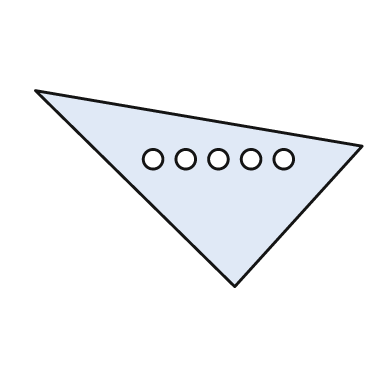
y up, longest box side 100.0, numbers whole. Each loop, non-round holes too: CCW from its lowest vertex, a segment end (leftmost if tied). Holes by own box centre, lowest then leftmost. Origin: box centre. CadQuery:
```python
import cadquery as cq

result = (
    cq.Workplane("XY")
    .moveTo(11.0, -30.0)
    .lineTo(50.0, 13.0)
    .lineTo(-50.0, 30.0)
    .close()
    .moveTo(-14.0, 9.0)
    .circle(3.0)
    .moveTo(-4.0, 9.0)
    .circle(3.0)
    .moveTo(6.0, 9.0)
    .circle(3.0)
    .moveTo(16.0, 9.0)
    .circle(3.0)
    .moveTo(26.0, 9.0)
    .circle(3.0)
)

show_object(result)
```